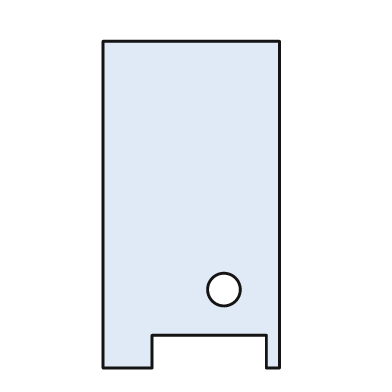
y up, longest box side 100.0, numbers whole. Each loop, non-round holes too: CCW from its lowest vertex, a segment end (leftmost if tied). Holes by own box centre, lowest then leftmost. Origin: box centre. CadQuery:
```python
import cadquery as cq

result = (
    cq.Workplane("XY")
    .moveTo(-27.0, -50.0)
    .lineTo(-12.0, -50.0)
    .lineTo(-12.0, -40.0)
    .lineTo(23.0, -40.0)
    .lineTo(23.0, -50.0)
    .lineTo(27.0, -50.0)
    .lineTo(27.0, 50.0)
    .lineTo(-27.0, 50.0)
    .close()
    .moveTo(10.0, -26.0)
    .circle(5.0)
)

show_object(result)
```